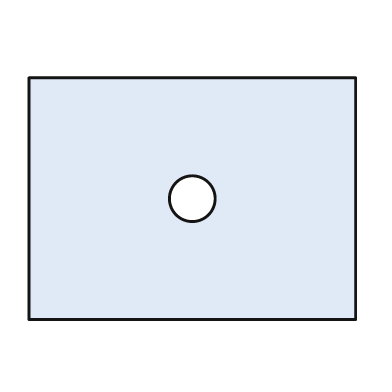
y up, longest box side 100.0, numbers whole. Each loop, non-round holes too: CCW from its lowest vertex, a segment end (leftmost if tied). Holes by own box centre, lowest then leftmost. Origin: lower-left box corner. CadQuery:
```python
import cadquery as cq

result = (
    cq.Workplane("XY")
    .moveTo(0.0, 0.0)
    .lineTo(100.0, 0.0)
    .lineTo(100.0, 74.0)
    .lineTo(0.0, 74.0)
    .close()
    .moveTo(50.0, 37.0)
    .circle(7.0)
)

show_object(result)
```